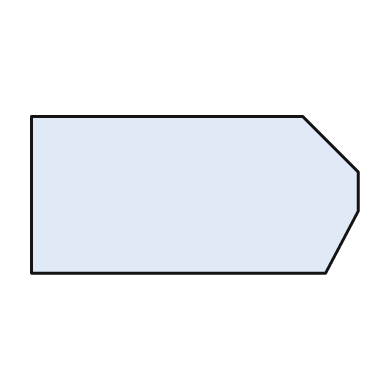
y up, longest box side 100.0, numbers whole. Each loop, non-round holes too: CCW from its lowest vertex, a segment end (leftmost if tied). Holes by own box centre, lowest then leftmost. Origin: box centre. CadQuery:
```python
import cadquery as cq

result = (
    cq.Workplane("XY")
    .moveTo(-50.0, -24.0)
    .lineTo(40.0, -24.0)
    .lineTo(50.0, -5.0)
    .lineTo(50.0, 7.0)
    .lineTo(33.0, 24.0)
    .lineTo(-50.0, 24.0)
    .close()
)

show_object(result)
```